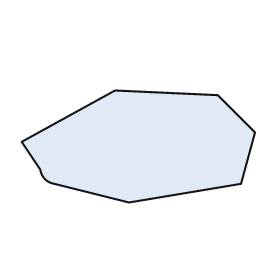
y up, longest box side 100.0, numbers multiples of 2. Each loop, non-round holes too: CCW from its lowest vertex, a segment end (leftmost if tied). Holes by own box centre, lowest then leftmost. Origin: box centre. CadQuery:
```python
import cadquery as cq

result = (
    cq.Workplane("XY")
    .moveTo(-4.0, -24.0)
    .lineTo(44.0, -16.0)
    .lineTo(50.0, 6.0)
    .lineTo(34.0, 22.0)
    .lineTo(-10.0, 24.0)
    .lineTo(-50.0, 2.0)
    .lineTo(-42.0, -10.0)
    .threePointArc((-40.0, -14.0), (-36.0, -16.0))
    .close()
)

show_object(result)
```